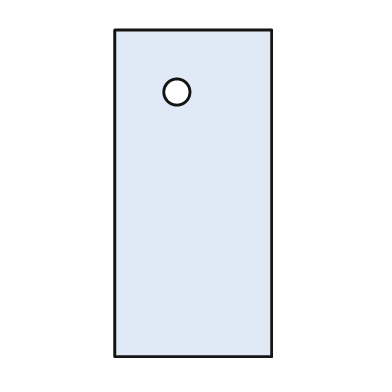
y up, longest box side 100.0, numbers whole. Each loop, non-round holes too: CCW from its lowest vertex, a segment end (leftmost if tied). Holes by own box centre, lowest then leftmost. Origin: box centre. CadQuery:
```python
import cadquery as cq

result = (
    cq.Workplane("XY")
    .moveTo(-24.0, -50.0)
    .lineTo(24.0, -50.0)
    .lineTo(24.0, 50.0)
    .lineTo(-24.0, 50.0)
    .close()
    .moveTo(-5.0, 31.0)
    .circle(4.0)
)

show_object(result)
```